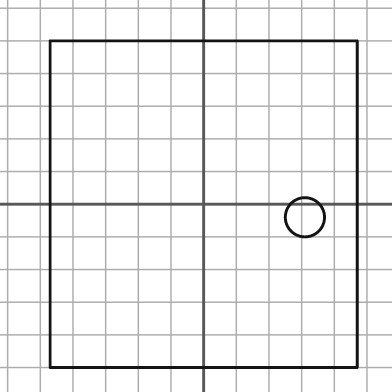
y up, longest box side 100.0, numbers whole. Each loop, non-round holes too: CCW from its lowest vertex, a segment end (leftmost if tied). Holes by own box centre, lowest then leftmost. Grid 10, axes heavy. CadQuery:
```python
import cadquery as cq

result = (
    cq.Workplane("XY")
    .moveTo(-47.0, -50.0)
    .lineTo(47.0, -50.0)
    .lineTo(47.0, 50.0)
    .lineTo(-47.0, 50.0)
    .close()
    .moveTo(31.0, -4.0)
    .circle(6.0)
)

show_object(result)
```